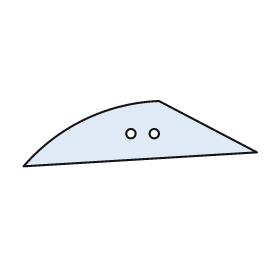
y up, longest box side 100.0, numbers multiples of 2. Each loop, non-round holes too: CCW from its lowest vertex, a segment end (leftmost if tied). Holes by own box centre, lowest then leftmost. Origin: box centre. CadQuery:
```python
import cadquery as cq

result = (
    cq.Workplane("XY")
    .moveTo(-50.0, -14.0)
    .lineTo(50.0, -8.0)
    .lineTo(8.0, 14.0)
    .threePointArc((-24.0, 6.0), (-50.0, -14.0))
    .close()
    .moveTo(-4.0, 0.0)
    .circle(2.0)
    .moveTo(6.0, 0.0)
    .circle(2.0)
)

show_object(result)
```